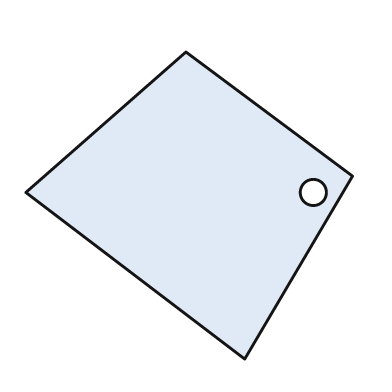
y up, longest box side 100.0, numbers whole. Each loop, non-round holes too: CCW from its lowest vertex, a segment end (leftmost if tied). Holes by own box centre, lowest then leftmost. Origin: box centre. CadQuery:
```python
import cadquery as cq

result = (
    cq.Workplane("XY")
    .moveTo(17.0, -47.0)
    .lineTo(50.0, 9.0)
    .lineTo(-1.0, 47.0)
    .lineTo(-50.0, 4.0)
    .close()
    .moveTo(38.0, 4.0)
    .circle(4.0)
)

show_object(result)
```